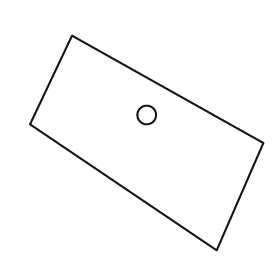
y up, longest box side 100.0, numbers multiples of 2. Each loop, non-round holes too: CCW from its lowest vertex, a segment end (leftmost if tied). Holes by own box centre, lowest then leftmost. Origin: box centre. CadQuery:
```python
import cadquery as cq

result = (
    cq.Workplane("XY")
    .moveTo(30.0, -46.0)
    .lineTo(50.0, 0.0)
    .lineTo(-32.0, 46.0)
    .lineTo(-50.0, 8.0)
    .close()
    .moveTo(0.0, 12.0)
    .circle(4.0)
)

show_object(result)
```